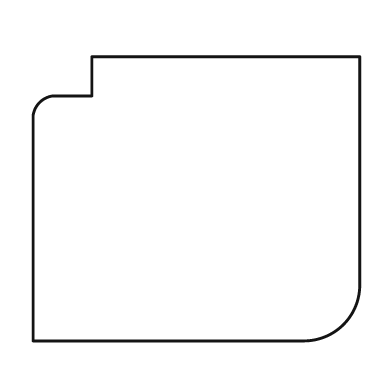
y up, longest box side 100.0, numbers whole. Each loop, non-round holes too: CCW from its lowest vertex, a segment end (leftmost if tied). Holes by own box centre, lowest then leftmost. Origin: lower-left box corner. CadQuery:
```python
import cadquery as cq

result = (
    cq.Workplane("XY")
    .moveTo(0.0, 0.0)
    .lineTo(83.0, 0.0)
    .threePointArc((95.0, 5.0), (100.0, 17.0))
    .lineTo(100.0, 87.0)
    .lineTo(18.0, 87.0)
    .lineTo(18.0, 75.0)
    .lineTo(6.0, 75.0)
    .threePointArc((2.0, 73.0), (0.0, 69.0))
    .close()
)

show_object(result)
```